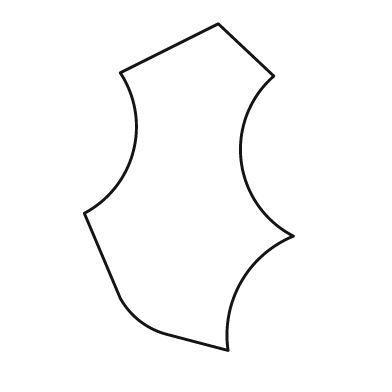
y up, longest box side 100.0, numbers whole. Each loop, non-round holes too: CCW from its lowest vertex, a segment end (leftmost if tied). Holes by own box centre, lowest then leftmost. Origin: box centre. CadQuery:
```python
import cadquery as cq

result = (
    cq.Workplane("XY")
    .moveTo(12.0, -50.0)
    .threePointArc((16.0, -29.0), (32.0, -15.0))
    .threePointArc((16.0, 8.0), (26.0, 34.0))
    .lineTo(9.0, 50.0)
    .lineTo(-21.0, 35.0)
    .threePointArc((-17.0, 11.0), (-32.0, -8.0))
    .lineTo(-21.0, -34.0)
    .threePointArc((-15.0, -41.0), (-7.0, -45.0))
    .close()
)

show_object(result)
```